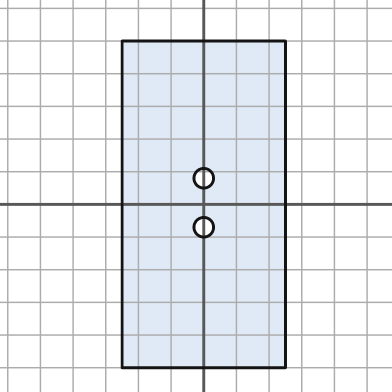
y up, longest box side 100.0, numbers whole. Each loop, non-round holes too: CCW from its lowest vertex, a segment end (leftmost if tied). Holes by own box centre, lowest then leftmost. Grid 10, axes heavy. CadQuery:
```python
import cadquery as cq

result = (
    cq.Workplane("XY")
    .moveTo(-25.0, -50.0)
    .lineTo(25.0, -50.0)
    .lineTo(25.0, 50.0)
    .lineTo(-25.0, 50.0)
    .close()
    .moveTo(0.0, -7.0)
    .circle(3.0)
    .moveTo(0.0, 8.0)
    .circle(3.0)
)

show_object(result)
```